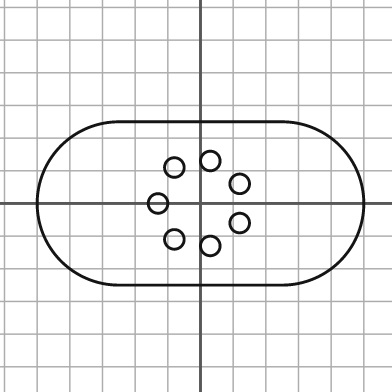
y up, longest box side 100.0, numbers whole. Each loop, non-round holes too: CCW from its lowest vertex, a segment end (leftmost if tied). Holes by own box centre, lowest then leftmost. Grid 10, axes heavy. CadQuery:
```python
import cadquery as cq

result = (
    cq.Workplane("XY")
    .moveTo(-25.0, -25.0)
    .lineTo(25.0, -25.0)
    .threePointArc((50.0, 0.0), (25.0, 25.0))
    .lineTo(-25.0, 25.0)
    .threePointArc((-50.0, 0.0), (-25.0, -25.0))
    .close()
    .moveTo(3.0, -13.0)
    .circle(3.0)
    .moveTo(-8.0, -11.0)
    .circle(3.0)
    .moveTo(12.0, -6.0)
    .circle(3.0)
    .moveTo(-13.0, 0.0)
    .circle(3.0)
    .moveTo(12.0, 6.0)
    .circle(3.0)
    .moveTo(-8.0, 11.0)
    .circle(3.0)
    .moveTo(3.0, 13.0)
    .circle(3.0)
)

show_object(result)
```